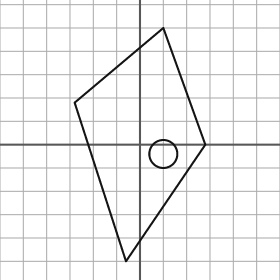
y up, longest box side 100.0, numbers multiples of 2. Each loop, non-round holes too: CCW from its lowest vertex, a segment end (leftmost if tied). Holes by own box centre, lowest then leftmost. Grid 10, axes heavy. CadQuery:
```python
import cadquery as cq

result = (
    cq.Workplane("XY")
    .moveTo(-6.0, -50.0)
    .lineTo(28.0, 0.0)
    .lineTo(10.0, 50.0)
    .lineTo(-28.0, 18.0)
    .close()
    .moveTo(10.0, -4.0)
    .circle(6.0)
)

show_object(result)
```